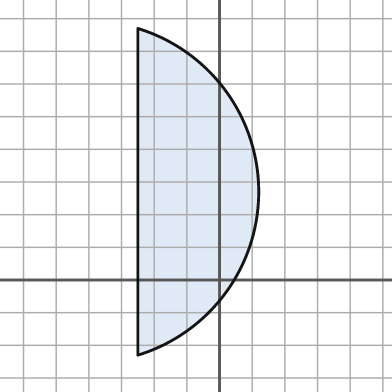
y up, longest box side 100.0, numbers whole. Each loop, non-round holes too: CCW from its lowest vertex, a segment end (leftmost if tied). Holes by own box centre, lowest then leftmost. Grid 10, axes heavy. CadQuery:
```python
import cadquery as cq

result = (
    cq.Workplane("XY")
    .moveTo(-25.0, -23.0)
    .threePointArc((12.0, 27.0), (-25.0, 77.0))
    .close()
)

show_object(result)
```